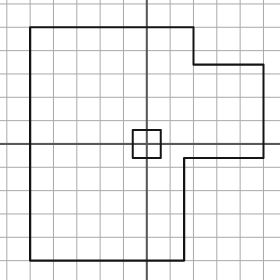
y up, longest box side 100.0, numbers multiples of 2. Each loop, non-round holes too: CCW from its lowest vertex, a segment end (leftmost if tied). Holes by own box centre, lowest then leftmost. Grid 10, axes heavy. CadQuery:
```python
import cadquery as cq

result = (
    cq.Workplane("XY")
    .moveTo(-50.0, -50.0)
    .lineTo(16.0, -50.0)
    .lineTo(16.0, -6.0)
    .lineTo(50.0, -6.0)
    .lineTo(50.0, 34.0)
    .lineTo(20.0, 34.0)
    .lineTo(20.0, 50.0)
    .lineTo(-50.0, 50.0)
    .close()
    .moveTo(-6.0, -6.0)
    .lineTo(6.0, -6.0)
    .lineTo(6.0, 6.0)
    .lineTo(-6.0, 6.0)
    .close()
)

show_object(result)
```